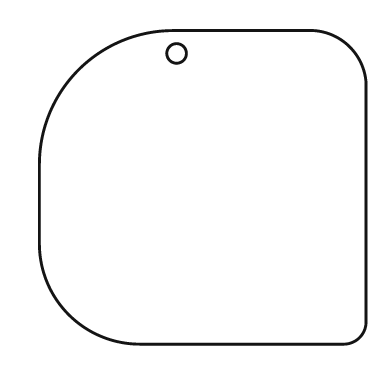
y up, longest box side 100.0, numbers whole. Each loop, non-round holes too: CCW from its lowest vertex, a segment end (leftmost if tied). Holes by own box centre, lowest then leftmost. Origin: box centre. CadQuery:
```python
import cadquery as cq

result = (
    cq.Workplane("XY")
    .moveTo(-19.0, -48.0)
    .lineTo(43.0, -48.0)
    .threePointArc((48.0, -46.0), (50.0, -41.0))
    .lineTo(50.0, 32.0)
    .threePointArc((45.0, 43.0), (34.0, 48.0))
    .lineTo(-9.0, 48.0)
    .threePointArc((-38.0, 36.0), (-50.0, 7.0))
    .lineTo(-50.0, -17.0)
    .threePointArc((-41.0, -39.0), (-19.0, -48.0))
    .close()
    .moveTo(-8.0, 41.0)
    .circle(3.0)
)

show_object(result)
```